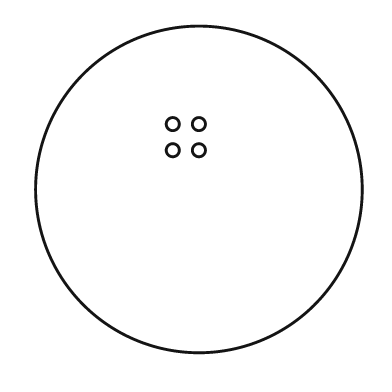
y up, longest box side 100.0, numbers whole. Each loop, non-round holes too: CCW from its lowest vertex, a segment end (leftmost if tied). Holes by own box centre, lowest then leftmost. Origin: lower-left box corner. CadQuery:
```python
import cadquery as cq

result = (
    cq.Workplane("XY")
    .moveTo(50.0, 50.0)
    .circle(50.0)
    .moveTo(42.0, 62.0)
    .circle(2.0)
    .moveTo(50.0, 62.0)
    .circle(2.0)
    .moveTo(42.0, 70.0)
    .circle(2.0)
    .moveTo(50.0, 70.0)
    .circle(2.0)
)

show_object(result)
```